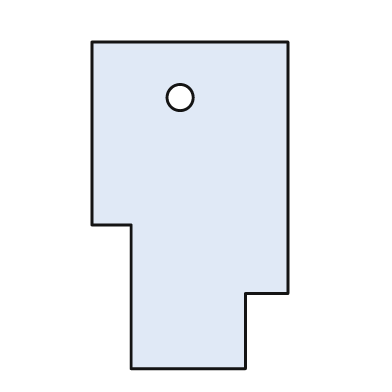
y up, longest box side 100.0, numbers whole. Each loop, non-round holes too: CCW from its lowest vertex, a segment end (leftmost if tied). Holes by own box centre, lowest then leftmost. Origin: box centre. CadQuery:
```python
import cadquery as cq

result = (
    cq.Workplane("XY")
    .moveTo(-18.0, -50.0)
    .lineTo(17.0, -50.0)
    .lineTo(17.0, -27.0)
    .lineTo(30.0, -27.0)
    .lineTo(30.0, 50.0)
    .lineTo(-30.0, 50.0)
    .lineTo(-30.0, -6.0)
    .lineTo(-18.0, -6.0)
    .close()
    .moveTo(-3.0, 33.0)
    .circle(4.0)
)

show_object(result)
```